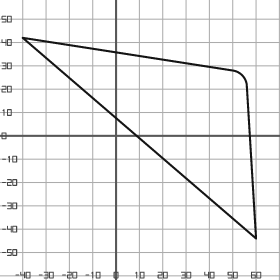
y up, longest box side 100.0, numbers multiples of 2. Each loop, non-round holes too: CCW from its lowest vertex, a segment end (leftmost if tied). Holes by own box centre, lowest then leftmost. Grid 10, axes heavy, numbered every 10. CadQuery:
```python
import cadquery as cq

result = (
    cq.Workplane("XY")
    .moveTo(60.0, -44.0)
    .lineTo(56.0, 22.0)
    .threePointArc((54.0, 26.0), (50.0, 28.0))
    .lineTo(-40.0, 42.0)
    .close()
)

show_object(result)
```